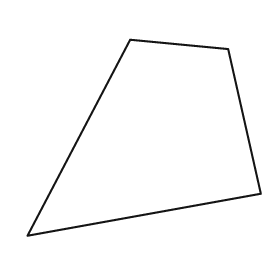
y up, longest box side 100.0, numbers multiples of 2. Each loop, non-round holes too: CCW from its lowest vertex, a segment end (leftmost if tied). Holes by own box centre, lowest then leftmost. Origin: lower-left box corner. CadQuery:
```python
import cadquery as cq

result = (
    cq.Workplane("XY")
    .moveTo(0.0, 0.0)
    .lineTo(100.0, 18.0)
    .lineTo(86.0, 80.0)
    .lineTo(44.0, 84.0)
    .close()
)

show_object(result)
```